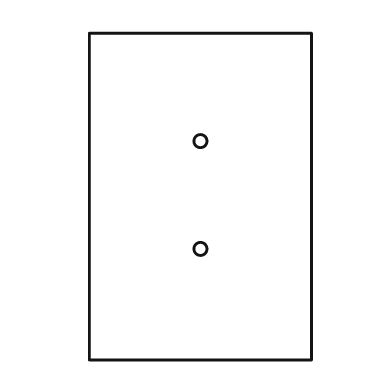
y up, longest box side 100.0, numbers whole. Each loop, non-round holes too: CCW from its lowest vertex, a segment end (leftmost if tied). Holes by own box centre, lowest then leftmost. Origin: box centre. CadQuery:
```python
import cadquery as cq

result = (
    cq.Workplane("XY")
    .moveTo(-34.0, -50.0)
    .lineTo(34.0, -50.0)
    .lineTo(34.0, 50.0)
    .lineTo(-34.0, 50.0)
    .close()
    .moveTo(0.0, -16.0)
    .circle(2.0)
    .moveTo(0.0, 17.0)
    .circle(2.0)
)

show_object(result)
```